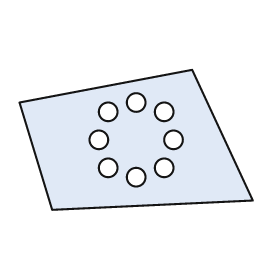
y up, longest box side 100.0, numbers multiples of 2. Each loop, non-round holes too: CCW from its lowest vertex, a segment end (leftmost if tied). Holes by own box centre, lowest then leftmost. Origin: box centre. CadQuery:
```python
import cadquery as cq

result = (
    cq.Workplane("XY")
    .moveTo(-36.0, -30.0)
    .lineTo(50.0, -26.0)
    .lineTo(24.0, 30.0)
    .lineTo(-50.0, 16.0)
    .close()
    .moveTo(0.0, -16.0)
    .circle(4.0)
    .moveTo(-12.0, -12.0)
    .circle(4.0)
    .moveTo(12.0, -12.0)
    .circle(4.0)
    .moveTo(-16.0, 0.0)
    .circle(4.0)
    .moveTo(16.0, 0.0)
    .circle(4.0)
    .moveTo(-12.0, 12.0)
    .circle(4.0)
    .moveTo(12.0, 12.0)
    .circle(4.0)
    .moveTo(0.0, 16.0)
    .circle(4.0)
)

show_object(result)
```